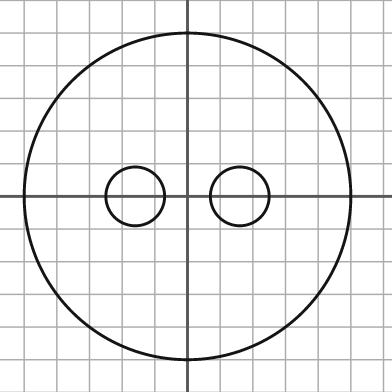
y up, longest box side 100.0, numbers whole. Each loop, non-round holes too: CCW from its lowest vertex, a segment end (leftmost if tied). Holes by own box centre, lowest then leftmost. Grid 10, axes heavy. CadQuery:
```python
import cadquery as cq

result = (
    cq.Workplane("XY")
    .moveTo(0.0, 0.0)
    .circle(50.0)
    .moveTo(-16.0, 0.0)
    .circle(9.0)
    .moveTo(16.0, 0.0)
    .circle(9.0)
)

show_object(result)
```